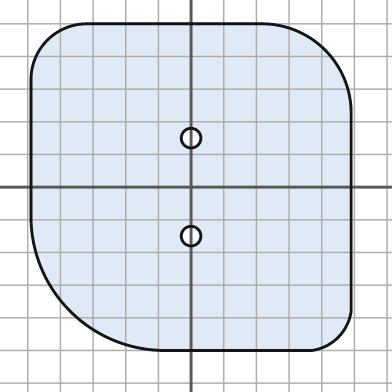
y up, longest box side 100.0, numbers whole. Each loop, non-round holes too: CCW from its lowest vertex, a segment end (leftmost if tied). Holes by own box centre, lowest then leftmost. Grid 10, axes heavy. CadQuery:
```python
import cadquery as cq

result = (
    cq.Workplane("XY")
    .moveTo(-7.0, -50.0)
    .lineTo(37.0, -50.0)
    .threePointArc((45.0, -46.0), (49.0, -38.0))
    .lineTo(49.0, 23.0)
    .threePointArc((41.0, 42.0), (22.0, 50.0))
    .lineTo(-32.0, 50.0)
    .threePointArc((-44.0, 45.0), (-49.0, 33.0))
    .lineTo(-49.0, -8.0)
    .threePointArc((-37.0, -38.0), (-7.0, -50.0))
    .close()
    .moveTo(0.0, -15.0)
    .circle(3.0)
    .moveTo(0.0, 15.0)
    .circle(3.0)
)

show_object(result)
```